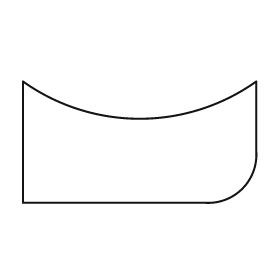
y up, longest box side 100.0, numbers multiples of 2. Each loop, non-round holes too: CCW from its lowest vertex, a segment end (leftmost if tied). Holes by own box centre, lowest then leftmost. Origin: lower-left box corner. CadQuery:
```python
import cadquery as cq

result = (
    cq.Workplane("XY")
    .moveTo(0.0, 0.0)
    .lineTo(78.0, 0.0)
    .threePointArc((94.0, 6.0), (100.0, 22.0))
    .lineTo(100.0, 52.0)
    .threePointArc((50.0, 36.0), (0.0, 52.0))
    .close()
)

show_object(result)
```